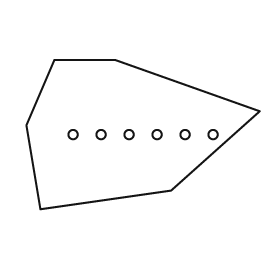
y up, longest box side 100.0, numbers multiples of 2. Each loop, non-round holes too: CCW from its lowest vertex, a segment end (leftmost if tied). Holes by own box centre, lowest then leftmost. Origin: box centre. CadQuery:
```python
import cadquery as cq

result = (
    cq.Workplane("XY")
    .moveTo(-44.0, -32.0)
    .lineTo(12.0, -24.0)
    .lineTo(50.0, 10.0)
    .lineTo(-12.0, 32.0)
    .lineTo(-38.0, 32.0)
    .lineTo(-50.0, 4.0)
    .close()
    .moveTo(-30.0, 0.0)
    .circle(2.0)
    .moveTo(-18.0, 0.0)
    .circle(2.0)
    .moveTo(-6.0, 0.0)
    .circle(2.0)
    .moveTo(6.0, 0.0)
    .circle(2.0)
    .moveTo(18.0, 0.0)
    .circle(2.0)
    .moveTo(30.0, 0.0)
    .circle(2.0)
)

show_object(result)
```